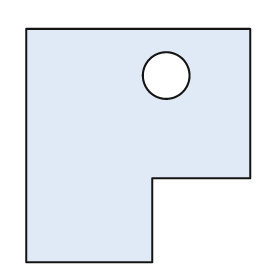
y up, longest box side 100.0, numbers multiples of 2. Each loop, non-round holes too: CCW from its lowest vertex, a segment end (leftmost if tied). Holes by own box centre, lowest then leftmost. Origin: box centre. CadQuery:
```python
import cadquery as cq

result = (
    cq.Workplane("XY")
    .moveTo(-48.0, -50.0)
    .lineTo(6.0, -50.0)
    .lineTo(6.0, -14.0)
    .lineTo(48.0, -14.0)
    .lineTo(48.0, 50.0)
    .lineTo(-48.0, 50.0)
    .close()
    .moveTo(12.0, 30.0)
    .circle(10.0)
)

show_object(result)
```